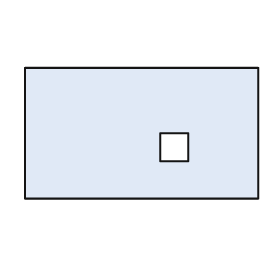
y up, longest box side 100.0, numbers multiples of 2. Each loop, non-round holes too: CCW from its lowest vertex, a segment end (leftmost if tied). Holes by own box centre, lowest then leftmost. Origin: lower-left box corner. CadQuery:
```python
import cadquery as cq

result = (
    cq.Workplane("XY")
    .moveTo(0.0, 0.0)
    .lineTo(100.0, 0.0)
    .lineTo(100.0, 56.0)
    .lineTo(0.0, 56.0)
    .close()
    .moveTo(58.0, 16.0)
    .lineTo(70.0, 16.0)
    .lineTo(70.0, 28.0)
    .lineTo(58.0, 28.0)
    .close()
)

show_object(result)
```